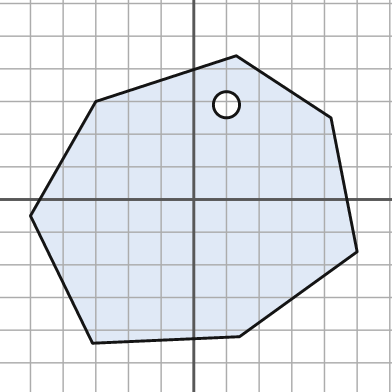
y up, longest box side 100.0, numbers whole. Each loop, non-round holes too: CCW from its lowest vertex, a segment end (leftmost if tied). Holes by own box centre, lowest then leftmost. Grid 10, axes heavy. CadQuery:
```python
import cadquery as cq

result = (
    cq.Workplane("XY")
    .moveTo(-31.0, -44.0)
    .lineTo(14.0, -42.0)
    .lineTo(50.0, -16.0)
    .lineTo(42.0, 25.0)
    .lineTo(13.0, 44.0)
    .lineTo(-30.0, 30.0)
    .lineTo(-50.0, -5.0)
    .close()
    .moveTo(10.0, 29.0)
    .circle(4.0)
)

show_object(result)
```